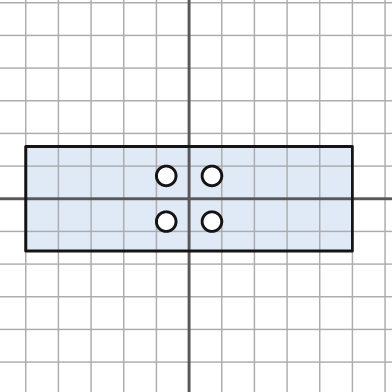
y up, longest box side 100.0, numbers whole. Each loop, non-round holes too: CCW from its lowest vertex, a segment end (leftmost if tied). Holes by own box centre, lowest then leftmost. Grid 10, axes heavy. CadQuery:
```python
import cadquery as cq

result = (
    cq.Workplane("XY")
    .moveTo(-50.0, -16.0)
    .lineTo(50.0, -16.0)
    .lineTo(50.0, 16.0)
    .lineTo(-50.0, 16.0)
    .close()
    .moveTo(-7.0, -7.0)
    .circle(3.0)
    .moveTo(7.0, -7.0)
    .circle(3.0)
    .moveTo(-7.0, 7.0)
    .circle(3.0)
    .moveTo(7.0, 7.0)
    .circle(3.0)
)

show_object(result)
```